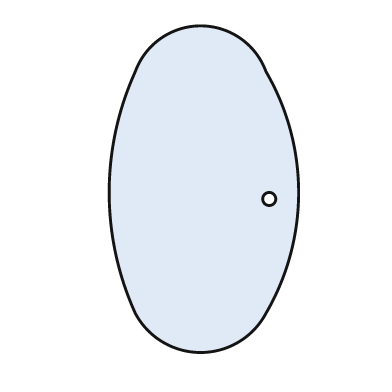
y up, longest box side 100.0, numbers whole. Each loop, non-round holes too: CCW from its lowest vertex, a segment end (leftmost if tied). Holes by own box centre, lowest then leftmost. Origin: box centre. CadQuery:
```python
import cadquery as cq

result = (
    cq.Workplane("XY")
    .moveTo(-21.0, -38.0)
    .threePointArc((-1.0, -50.0), (19.0, -38.0))
    .threePointArc((29.0, -1.0), (19.0, 36.0))
    .threePointArc((-1.0, 50.0), (-21.0, 36.0))
    .threePointArc((-29.0, -1.0), (-21.0, -38.0))
    .close()
    .moveTo(20.0, -3.0)
    .circle(2.0)
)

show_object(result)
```